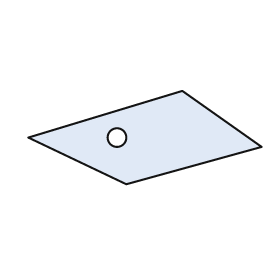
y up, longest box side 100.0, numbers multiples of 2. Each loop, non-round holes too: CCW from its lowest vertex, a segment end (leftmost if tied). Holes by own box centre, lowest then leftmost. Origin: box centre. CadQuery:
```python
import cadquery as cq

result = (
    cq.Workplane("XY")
    .moveTo(-8.0, -20.0)
    .lineTo(50.0, -4.0)
    .lineTo(16.0, 20.0)
    .lineTo(-50.0, 0.0)
    .close()
    .moveTo(-12.0, 0.0)
    .circle(4.0)
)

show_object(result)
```